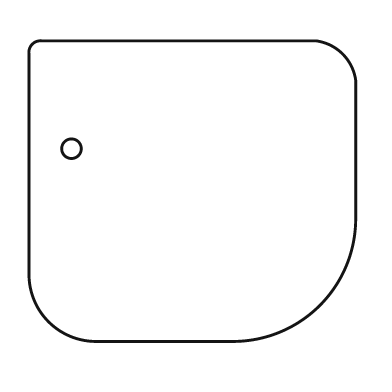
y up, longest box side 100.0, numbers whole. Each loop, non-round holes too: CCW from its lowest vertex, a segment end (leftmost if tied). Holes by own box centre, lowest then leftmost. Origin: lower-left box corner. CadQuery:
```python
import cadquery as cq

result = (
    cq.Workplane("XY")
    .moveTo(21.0, 0.0)
    .lineTo(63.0, 0.0)
    .threePointArc((89.0, 11.0), (100.0, 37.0))
    .lineTo(100.0, 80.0)
    .threePointArc((96.0, 88.0), (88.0, 92.0))
    .lineTo(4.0, 92.0)
    .threePointArc((1.0, 91.0), (0.0, 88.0))
    .lineTo(0.0, 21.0)
    .threePointArc((6.0, 6.0), (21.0, 0.0))
    .close()
    .moveTo(13.0, 59.0)
    .circle(3.0)
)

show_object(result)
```